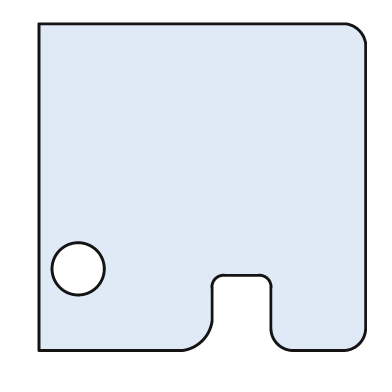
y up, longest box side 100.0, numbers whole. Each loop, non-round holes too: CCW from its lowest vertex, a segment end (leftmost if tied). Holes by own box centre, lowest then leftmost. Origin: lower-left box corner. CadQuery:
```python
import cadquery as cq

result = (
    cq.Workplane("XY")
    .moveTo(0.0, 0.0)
    .lineTo(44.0, 0.0)
    .threePointArc((50.0, 3.0), (53.0, 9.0))
    .lineTo(53.0, 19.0)
    .threePointArc((54.0, 22.0), (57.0, 23.0))
    .lineTo(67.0, 23.0)
    .threePointArc((70.0, 22.0), (71.0, 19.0))
    .lineTo(71.0, 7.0)
    .threePointArc((73.0, 2.0), (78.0, 0.0))
    .lineTo(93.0, 0.0)
    .threePointArc((98.0, 2.0), (100.0, 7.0))
    .lineTo(100.0, 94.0)
    .threePointArc((98.0, 98.0), (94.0, 100.0))
    .lineTo(0.0, 100.0)
    .close()
    .moveTo(12.0, 25.0)
    .circle(8.0)
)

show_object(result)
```